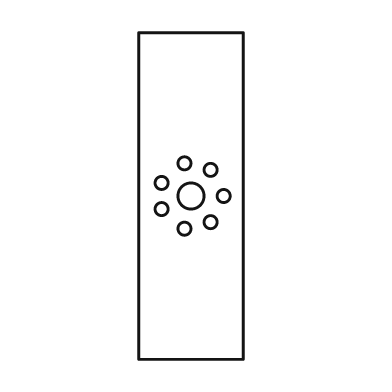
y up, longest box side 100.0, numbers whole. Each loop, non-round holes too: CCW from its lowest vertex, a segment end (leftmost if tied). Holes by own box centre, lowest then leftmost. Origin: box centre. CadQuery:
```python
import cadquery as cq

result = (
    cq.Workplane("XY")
    .moveTo(-16.0, -50.0)
    .lineTo(16.0, -50.0)
    .lineTo(16.0, 50.0)
    .lineTo(-16.0, 50.0)
    .close()
    .moveTo(-2.0, -10.0)
    .circle(2.0)
    .moveTo(6.0, -8.0)
    .circle(2.0)
    .moveTo(-9.0, -4.0)
    .circle(2.0)
    .moveTo(0.0, 0.0)
    .circle(4.0)
    .moveTo(10.0, 0.0)
    .circle(2.0)
    .moveTo(-9.0, 4.0)
    .circle(2.0)
    .moveTo(6.0, 8.0)
    .circle(2.0)
    .moveTo(-2.0, 10.0)
    .circle(2.0)
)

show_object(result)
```